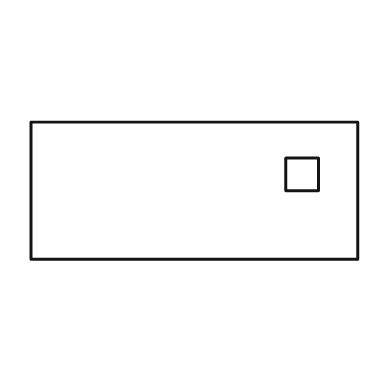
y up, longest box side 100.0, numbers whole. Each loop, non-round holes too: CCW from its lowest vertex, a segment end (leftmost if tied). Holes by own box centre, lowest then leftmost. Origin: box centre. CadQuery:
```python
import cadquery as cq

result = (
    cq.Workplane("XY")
    .moveTo(-50.0, -21.0)
    .lineTo(50.0, -21.0)
    .lineTo(50.0, 21.0)
    .lineTo(-50.0, 21.0)
    .close()
    .moveTo(28.0, 0.0)
    .lineTo(38.0, 0.0)
    .lineTo(38.0, 10.0)
    .lineTo(28.0, 10.0)
    .close()
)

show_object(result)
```